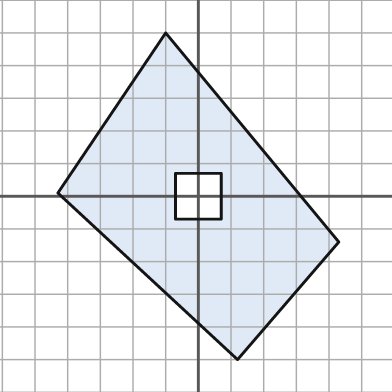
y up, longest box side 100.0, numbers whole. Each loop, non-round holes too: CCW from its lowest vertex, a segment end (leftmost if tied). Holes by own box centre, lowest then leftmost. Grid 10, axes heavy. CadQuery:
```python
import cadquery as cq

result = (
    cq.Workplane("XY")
    .moveTo(12.0, -50.0)
    .lineTo(43.0, -14.0)
    .lineTo(-10.0, 50.0)
    .lineTo(-43.0, 1.0)
    .close()
    .moveTo(-7.0, -7.0)
    .lineTo(7.0, -7.0)
    .lineTo(7.0, 7.0)
    .lineTo(-7.0, 7.0)
    .close()
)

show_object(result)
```